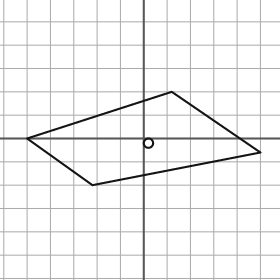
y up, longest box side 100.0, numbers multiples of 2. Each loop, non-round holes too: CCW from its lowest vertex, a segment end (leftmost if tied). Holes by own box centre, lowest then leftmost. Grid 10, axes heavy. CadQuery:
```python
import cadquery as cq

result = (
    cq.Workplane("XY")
    .moveTo(-22.0, -20.0)
    .lineTo(50.0, -6.0)
    .lineTo(12.0, 20.0)
    .lineTo(-50.0, 0.0)
    .close()
    .moveTo(2.0, -2.0)
    .circle(2.0)
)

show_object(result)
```